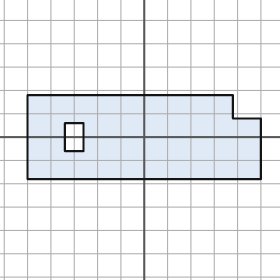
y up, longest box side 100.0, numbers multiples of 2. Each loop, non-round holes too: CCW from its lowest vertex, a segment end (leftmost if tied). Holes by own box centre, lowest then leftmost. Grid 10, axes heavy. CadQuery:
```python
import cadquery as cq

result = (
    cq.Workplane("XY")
    .moveTo(-50.0, -18.0)
    .lineTo(50.0, -18.0)
    .lineTo(50.0, 8.0)
    .lineTo(38.0, 8.0)
    .lineTo(38.0, 18.0)
    .lineTo(-50.0, 18.0)
    .close()
    .moveTo(-34.0, -6.0)
    .lineTo(-26.0, -6.0)
    .lineTo(-26.0, 6.0)
    .lineTo(-34.0, 6.0)
    .close()
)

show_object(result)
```